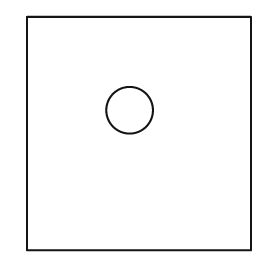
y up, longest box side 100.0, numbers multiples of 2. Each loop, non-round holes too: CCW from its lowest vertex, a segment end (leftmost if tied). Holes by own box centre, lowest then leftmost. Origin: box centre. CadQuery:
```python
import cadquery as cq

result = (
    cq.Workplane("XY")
    .moveTo(-48.0, -50.0)
    .lineTo(48.0, -50.0)
    .lineTo(48.0, 50.0)
    .lineTo(-48.0, 50.0)
    .close()
    .moveTo(-4.0, 10.0)
    .circle(10.0)
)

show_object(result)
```